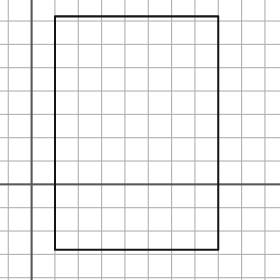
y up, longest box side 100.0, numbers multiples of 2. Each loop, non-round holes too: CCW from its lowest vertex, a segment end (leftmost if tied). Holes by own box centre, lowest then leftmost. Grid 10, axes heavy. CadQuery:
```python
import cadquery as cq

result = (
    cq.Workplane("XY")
    .moveTo(10.0, -28.0)
    .lineTo(80.0, -28.0)
    .lineTo(80.0, 72.0)
    .lineTo(10.0, 72.0)
    .close()
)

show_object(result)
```